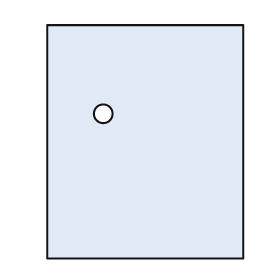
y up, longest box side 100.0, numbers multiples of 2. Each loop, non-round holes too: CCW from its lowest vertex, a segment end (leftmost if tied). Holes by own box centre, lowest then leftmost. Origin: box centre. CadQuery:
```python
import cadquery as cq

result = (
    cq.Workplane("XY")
    .moveTo(-42.0, -50.0)
    .lineTo(42.0, -50.0)
    .lineTo(42.0, 50.0)
    .lineTo(-42.0, 50.0)
    .close()
    .moveTo(-18.0, 12.0)
    .circle(4.0)
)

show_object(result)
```